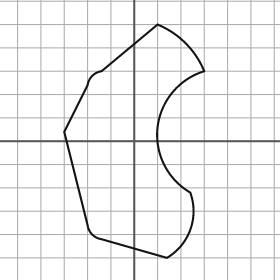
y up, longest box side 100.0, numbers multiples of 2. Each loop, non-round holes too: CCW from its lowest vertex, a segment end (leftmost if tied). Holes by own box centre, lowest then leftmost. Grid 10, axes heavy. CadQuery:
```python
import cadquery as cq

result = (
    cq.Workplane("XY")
    .moveTo(14.0, -50.0)
    .threePointArc((24.0, -38.0), (24.0, -22.0))
    .threePointArc((10.0, 6.0), (30.0, 30.0))
    .threePointArc((22.0, 42.0), (10.0, 50.0))
    .lineTo(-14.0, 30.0)
    .threePointArc((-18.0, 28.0), (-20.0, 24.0))
    .lineTo(-30.0, 4.0)
    .lineTo(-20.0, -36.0)
    .threePointArc((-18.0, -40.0), (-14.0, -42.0))
    .close()
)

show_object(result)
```